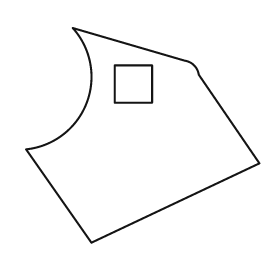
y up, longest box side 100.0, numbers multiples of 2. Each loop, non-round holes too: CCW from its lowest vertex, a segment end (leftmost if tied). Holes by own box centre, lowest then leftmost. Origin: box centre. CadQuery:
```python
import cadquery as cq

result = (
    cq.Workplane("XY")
    .moveTo(-22.0, -46.0)
    .lineTo(50.0, -12.0)
    .lineTo(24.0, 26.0)
    .threePointArc((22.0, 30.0), (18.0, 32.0))
    .lineTo(-30.0, 46.0)
    .threePointArc((-24.0, 14.0), (-50.0, -6.0))
    .close()
    .moveTo(-12.0, 14.0)
    .lineTo(4.0, 14.0)
    .lineTo(4.0, 30.0)
    .lineTo(-12.0, 30.0)
    .close()
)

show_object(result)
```